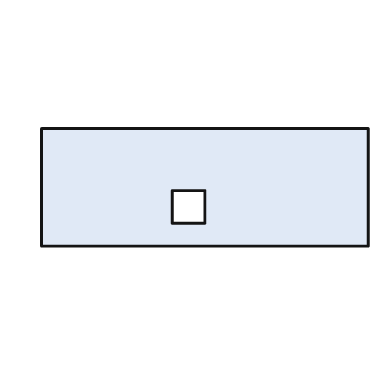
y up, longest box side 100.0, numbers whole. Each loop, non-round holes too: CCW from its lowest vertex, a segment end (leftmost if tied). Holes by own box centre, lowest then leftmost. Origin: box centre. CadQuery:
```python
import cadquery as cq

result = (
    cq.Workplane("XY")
    .moveTo(-50.0, -18.0)
    .lineTo(50.0, -18.0)
    .lineTo(50.0, 18.0)
    .lineTo(-50.0, 18.0)
    .close()
    .moveTo(-10.0, -11.0)
    .lineTo(0.0, -11.0)
    .lineTo(0.0, -1.0)
    .lineTo(-10.0, -1.0)
    .close()
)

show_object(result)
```